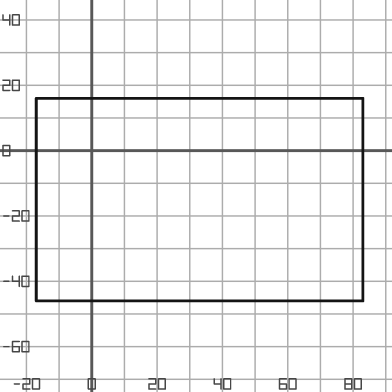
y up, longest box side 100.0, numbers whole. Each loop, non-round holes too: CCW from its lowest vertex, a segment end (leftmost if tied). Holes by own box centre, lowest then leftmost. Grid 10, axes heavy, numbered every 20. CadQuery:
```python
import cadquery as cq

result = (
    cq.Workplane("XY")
    .moveTo(-17.0, -46.0)
    .lineTo(83.0, -46.0)
    .lineTo(83.0, 16.0)
    .lineTo(-17.0, 16.0)
    .close()
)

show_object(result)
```